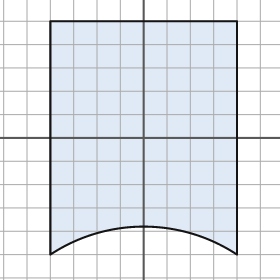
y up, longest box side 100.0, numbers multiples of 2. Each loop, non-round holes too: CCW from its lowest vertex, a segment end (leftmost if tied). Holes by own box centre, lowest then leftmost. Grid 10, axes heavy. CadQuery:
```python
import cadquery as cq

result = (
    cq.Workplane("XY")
    .moveTo(-40.0, -50.0)
    .threePointArc((0.0, -38.0), (40.0, -50.0))
    .lineTo(40.0, 50.0)
    .lineTo(-40.0, 50.0)
    .close()
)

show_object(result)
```